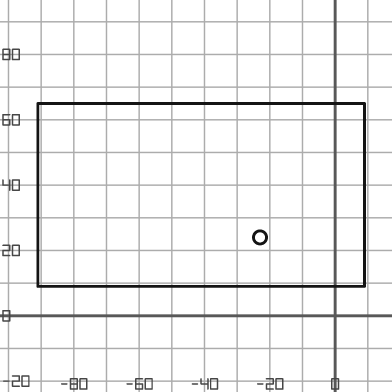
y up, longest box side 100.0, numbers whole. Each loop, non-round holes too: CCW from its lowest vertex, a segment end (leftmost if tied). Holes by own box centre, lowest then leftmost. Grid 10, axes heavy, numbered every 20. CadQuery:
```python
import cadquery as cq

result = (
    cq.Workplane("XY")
    .moveTo(-91.0, 9.0)
    .lineTo(9.0, 9.0)
    .lineTo(9.0, 65.0)
    .lineTo(-91.0, 65.0)
    .close()
    .moveTo(-23.0, 24.0)
    .circle(2.0)
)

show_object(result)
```